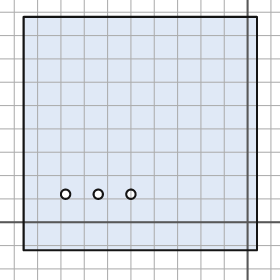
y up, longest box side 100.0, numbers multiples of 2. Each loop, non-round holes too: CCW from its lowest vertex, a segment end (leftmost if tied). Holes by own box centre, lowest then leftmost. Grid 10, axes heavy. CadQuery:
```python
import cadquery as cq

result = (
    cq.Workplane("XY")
    .moveTo(-96.0, -12.0)
    .lineTo(4.0, -12.0)
    .lineTo(4.0, 88.0)
    .lineTo(-96.0, 88.0)
    .close()
    .moveTo(-78.0, 12.0)
    .circle(2.0)
    .moveTo(-64.0, 12.0)
    .circle(2.0)
    .moveTo(-50.0, 12.0)
    .circle(2.0)
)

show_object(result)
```